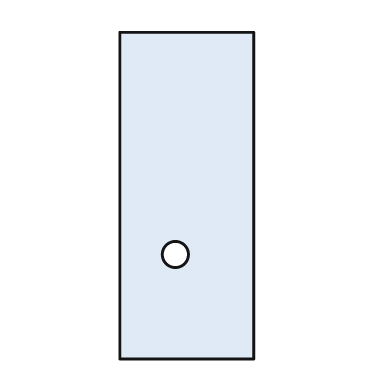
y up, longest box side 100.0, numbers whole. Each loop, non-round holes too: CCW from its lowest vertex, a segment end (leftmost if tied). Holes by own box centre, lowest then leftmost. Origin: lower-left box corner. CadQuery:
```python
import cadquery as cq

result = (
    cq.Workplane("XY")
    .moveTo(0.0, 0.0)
    .lineTo(41.0, 0.0)
    .lineTo(41.0, 100.0)
    .lineTo(0.0, 100.0)
    .close()
    .moveTo(17.0, 32.0)
    .circle(4.0)
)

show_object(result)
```